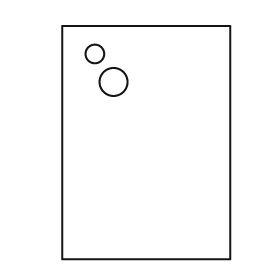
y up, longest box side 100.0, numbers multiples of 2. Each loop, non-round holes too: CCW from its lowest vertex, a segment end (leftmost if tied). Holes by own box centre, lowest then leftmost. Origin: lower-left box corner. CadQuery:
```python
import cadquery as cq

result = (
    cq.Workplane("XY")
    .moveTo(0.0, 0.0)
    .lineTo(72.0, 0.0)
    .lineTo(72.0, 100.0)
    .lineTo(0.0, 100.0)
    .close()
    .moveTo(22.0, 76.0)
    .circle(6.0)
    .moveTo(14.0, 88.0)
    .circle(4.0)
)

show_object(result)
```